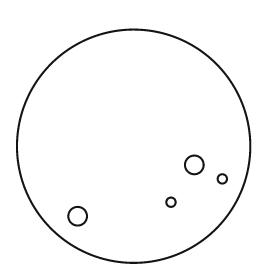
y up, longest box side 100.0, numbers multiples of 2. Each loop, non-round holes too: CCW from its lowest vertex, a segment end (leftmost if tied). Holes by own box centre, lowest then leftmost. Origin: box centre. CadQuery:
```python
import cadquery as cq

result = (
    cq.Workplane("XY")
    .moveTo(0.0, 0.0)
    .circle(50.0)
    .moveTo(-24.0, -30.0)
    .circle(4.0)
    .moveTo(16.0, -24.0)
    .circle(2.0)
    .moveTo(38.0, -14.0)
    .circle(2.0)
    .moveTo(26.0, -8.0)
    .circle(4.0)
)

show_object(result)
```